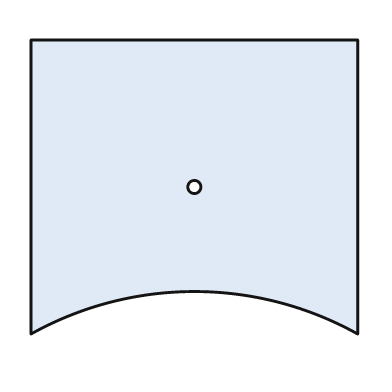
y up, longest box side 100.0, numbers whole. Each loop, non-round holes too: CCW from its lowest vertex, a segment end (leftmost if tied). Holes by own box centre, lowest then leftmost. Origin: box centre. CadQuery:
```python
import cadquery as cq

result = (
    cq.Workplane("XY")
    .moveTo(-50.0, -45.0)
    .threePointArc((0.0, -32.0), (50.0, -45.0))
    .lineTo(50.0, 45.0)
    .lineTo(-50.0, 45.0)
    .close()
    .moveTo(0.0, 0.0)
    .circle(2.0)
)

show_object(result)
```